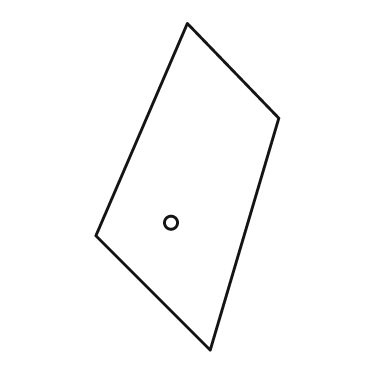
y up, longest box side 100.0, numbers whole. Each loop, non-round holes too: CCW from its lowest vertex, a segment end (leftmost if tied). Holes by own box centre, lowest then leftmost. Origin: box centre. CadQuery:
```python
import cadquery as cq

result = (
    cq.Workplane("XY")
    .moveTo(7.0, -50.0)
    .lineTo(28.0, 21.0)
    .lineTo(0.0, 50.0)
    .lineTo(-28.0, -15.0)
    .close()
    .moveTo(-5.0, -11.0)
    .circle(2.0)
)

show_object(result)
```